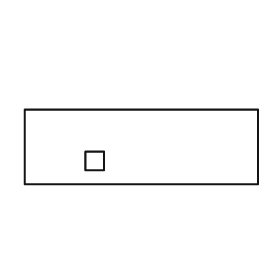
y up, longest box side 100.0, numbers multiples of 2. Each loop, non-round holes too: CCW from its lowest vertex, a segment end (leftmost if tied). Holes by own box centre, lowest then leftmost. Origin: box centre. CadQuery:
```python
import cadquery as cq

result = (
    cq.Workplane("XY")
    .moveTo(-50.0, -16.0)
    .lineTo(50.0, -16.0)
    .lineTo(50.0, 16.0)
    .lineTo(-50.0, 16.0)
    .close()
    .moveTo(-24.0, -10.0)
    .lineTo(-16.0, -10.0)
    .lineTo(-16.0, -2.0)
    .lineTo(-24.0, -2.0)
    .close()
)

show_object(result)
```